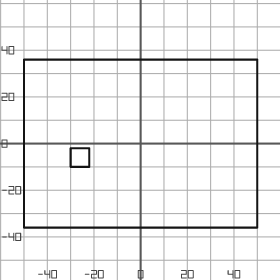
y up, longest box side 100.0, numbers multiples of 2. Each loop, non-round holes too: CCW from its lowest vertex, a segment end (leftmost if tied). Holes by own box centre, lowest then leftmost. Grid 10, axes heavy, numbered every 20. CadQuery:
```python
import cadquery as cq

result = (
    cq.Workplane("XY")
    .moveTo(-50.0, -36.0)
    .lineTo(50.0, -36.0)
    .lineTo(50.0, 36.0)
    .lineTo(-50.0, 36.0)
    .close()
    .moveTo(-30.0, -10.0)
    .lineTo(-22.0, -10.0)
    .lineTo(-22.0, -2.0)
    .lineTo(-30.0, -2.0)
    .close()
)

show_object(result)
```